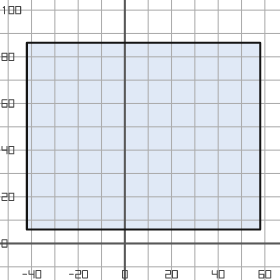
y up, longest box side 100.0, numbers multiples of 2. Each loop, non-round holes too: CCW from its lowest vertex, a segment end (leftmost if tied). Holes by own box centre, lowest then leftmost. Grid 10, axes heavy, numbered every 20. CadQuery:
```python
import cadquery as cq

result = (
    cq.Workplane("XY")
    .moveTo(-42.0, 6.0)
    .lineTo(58.0, 6.0)
    .lineTo(58.0, 86.0)
    .lineTo(-42.0, 86.0)
    .close()
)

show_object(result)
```